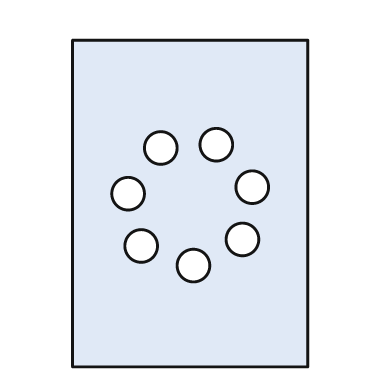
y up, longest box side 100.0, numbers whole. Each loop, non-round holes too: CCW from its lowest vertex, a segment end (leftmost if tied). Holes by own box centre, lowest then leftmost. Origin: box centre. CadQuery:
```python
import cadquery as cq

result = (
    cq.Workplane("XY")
    .moveTo(-36.0, -50.0)
    .lineTo(36.0, -50.0)
    .lineTo(36.0, 50.0)
    .lineTo(-36.0, 50.0)
    .close()
    .moveTo(1.0, -19.0)
    .circle(5.0)
    .moveTo(-15.0, -13.0)
    .circle(5.0)
    .moveTo(16.0, -11.0)
    .circle(5.0)
    .moveTo(-19.0, 3.0)
    .circle(5.0)
    .moveTo(19.0, 5.0)
    .circle(5.0)
    .moveTo(-9.0, 17.0)
    .circle(5.0)
    .moveTo(8.0, 18.0)
    .circle(5.0)
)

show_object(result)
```